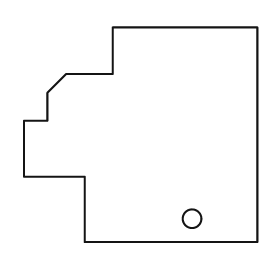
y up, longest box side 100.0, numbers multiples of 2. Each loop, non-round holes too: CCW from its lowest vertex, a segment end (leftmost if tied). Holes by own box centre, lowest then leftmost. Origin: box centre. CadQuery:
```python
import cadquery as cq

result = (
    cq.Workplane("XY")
    .moveTo(-24.0, -46.0)
    .lineTo(50.0, -46.0)
    .lineTo(50.0, 46.0)
    .lineTo(-12.0, 46.0)
    .lineTo(-12.0, 26.0)
    .lineTo(-32.0, 26.0)
    .lineTo(-40.0, 18.0)
    .lineTo(-40.0, 6.0)
    .lineTo(-50.0, 6.0)
    .lineTo(-50.0, -18.0)
    .lineTo(-24.0, -18.0)
    .close()
    .moveTo(22.0, -36.0)
    .circle(4.0)
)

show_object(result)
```